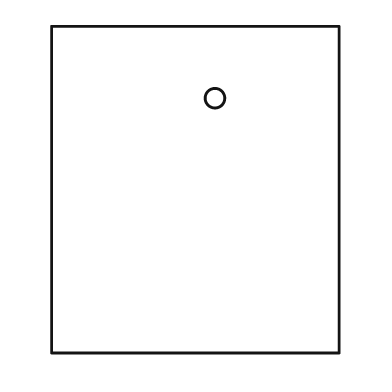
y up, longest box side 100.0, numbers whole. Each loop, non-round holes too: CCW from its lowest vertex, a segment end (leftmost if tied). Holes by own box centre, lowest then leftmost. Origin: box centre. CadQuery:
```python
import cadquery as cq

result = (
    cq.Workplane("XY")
    .moveTo(-44.0, -50.0)
    .lineTo(44.0, -50.0)
    .lineTo(44.0, 50.0)
    .lineTo(-44.0, 50.0)
    .close()
    .moveTo(6.0, 28.0)
    .circle(3.0)
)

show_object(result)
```